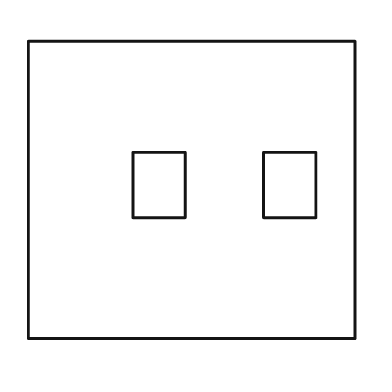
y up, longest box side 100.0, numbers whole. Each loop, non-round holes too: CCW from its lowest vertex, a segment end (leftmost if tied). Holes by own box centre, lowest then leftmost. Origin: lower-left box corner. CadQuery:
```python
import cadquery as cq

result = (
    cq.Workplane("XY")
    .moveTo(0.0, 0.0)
    .lineTo(100.0, 0.0)
    .lineTo(100.0, 91.0)
    .lineTo(0.0, 91.0)
    .close()
    .moveTo(32.0, 37.0)
    .lineTo(48.0, 37.0)
    .lineTo(48.0, 57.0)
    .lineTo(32.0, 57.0)
    .close()
    .moveTo(72.0, 37.0)
    .lineTo(88.0, 37.0)
    .lineTo(88.0, 57.0)
    .lineTo(72.0, 57.0)
    .close()
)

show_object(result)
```